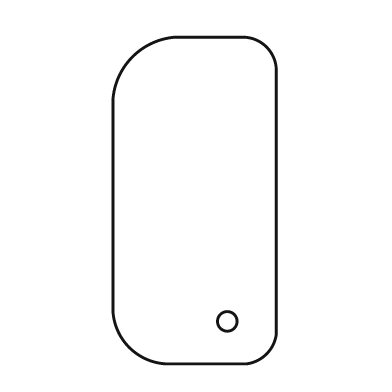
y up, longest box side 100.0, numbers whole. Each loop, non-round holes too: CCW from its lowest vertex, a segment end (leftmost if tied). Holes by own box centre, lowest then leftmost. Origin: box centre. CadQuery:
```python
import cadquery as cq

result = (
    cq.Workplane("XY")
    .moveTo(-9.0, -50.0)
    .lineTo(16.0, -50.0)
    .threePointArc((22.0, -47.0), (25.0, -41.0))
    .lineTo(25.0, 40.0)
    .threePointArc((22.0, 47.0), (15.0, 50.0))
    .lineTo(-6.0, 50.0)
    .threePointArc((-19.0, 44.0), (-25.0, 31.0))
    .lineTo(-25.0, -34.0)
    .threePointArc((-20.0, -45.0), (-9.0, -50.0))
    .close()
    .moveTo(10.0, -37.0)
    .circle(3.0)
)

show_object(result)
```